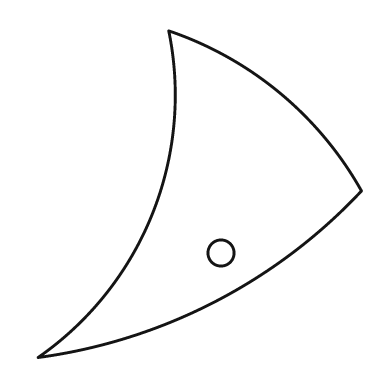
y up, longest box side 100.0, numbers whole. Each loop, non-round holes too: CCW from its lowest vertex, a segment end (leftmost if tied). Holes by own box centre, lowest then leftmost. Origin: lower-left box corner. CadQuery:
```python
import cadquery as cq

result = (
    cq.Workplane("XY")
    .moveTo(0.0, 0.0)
    .threePointArc((54.0, 17.0), (99.0, 51.0))
    .threePointArc((74.0, 81.0), (40.0, 100.0))
    .threePointArc((35.0, 44.0), (0.0, 0.0))
    .close()
    .moveTo(56.0, 32.0)
    .circle(4.0)
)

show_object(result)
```